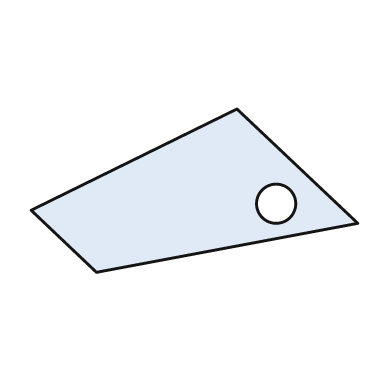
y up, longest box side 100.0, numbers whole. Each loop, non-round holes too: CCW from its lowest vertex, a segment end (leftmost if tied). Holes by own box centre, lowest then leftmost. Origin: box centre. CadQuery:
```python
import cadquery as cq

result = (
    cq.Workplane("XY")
    .moveTo(-30.0, -25.0)
    .lineTo(50.0, -10.0)
    .lineTo(13.0, 25.0)
    .lineTo(-50.0, -6.0)
    .close()
    .moveTo(25.0, -4.0)
    .circle(6.0)
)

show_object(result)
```